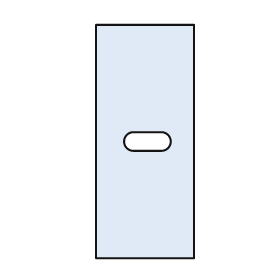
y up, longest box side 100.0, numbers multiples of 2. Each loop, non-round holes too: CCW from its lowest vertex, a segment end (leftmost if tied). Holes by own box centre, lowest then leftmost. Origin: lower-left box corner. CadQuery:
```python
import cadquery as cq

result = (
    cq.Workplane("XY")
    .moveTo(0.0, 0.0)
    .lineTo(42.0, 0.0)
    .lineTo(42.0, 100.0)
    .lineTo(0.0, 100.0)
    .close()
    .moveTo(16.0, 46.0)
    .lineTo(28.0, 46.0)
    .threePointArc((32.0, 50.0), (28.0, 54.0))
    .lineTo(16.0, 54.0)
    .threePointArc((12.0, 50.0), (16.0, 46.0))
    .close()
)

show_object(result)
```